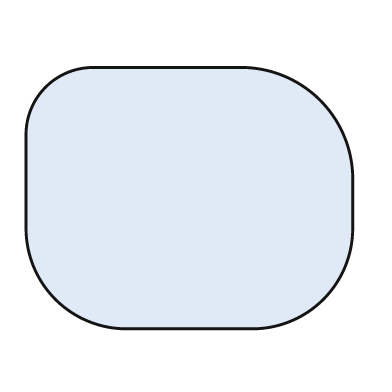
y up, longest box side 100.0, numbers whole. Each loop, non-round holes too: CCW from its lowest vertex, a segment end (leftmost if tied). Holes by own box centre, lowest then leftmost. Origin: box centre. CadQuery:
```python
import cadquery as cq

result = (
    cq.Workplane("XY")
    .moveTo(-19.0, -40.0)
    .lineTo(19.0, -40.0)
    .threePointArc((41.0, -31.0), (50.0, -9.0))
    .lineTo(50.0, 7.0)
    .threePointArc((40.0, 30.0), (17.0, 40.0))
    .lineTo(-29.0, 40.0)
    .threePointArc((-44.0, 34.0), (-50.0, 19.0))
    .lineTo(-50.0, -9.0)
    .threePointArc((-41.0, -31.0), (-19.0, -40.0))
    .close()
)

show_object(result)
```